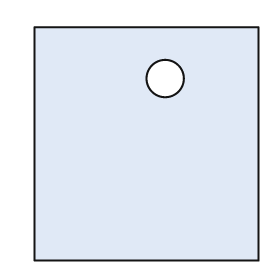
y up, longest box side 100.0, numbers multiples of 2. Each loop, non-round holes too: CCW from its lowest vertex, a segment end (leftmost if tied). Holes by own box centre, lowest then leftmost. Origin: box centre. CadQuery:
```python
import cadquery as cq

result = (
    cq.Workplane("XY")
    .moveTo(-48.0, -50.0)
    .lineTo(48.0, -50.0)
    .lineTo(48.0, 50.0)
    .lineTo(-48.0, 50.0)
    .close()
    .moveTo(8.0, 28.0)
    .circle(8.0)
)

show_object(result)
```